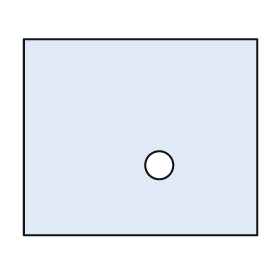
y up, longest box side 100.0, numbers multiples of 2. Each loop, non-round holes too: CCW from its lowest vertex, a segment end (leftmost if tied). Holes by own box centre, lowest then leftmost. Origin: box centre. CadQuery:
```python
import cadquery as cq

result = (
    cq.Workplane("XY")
    .moveTo(-50.0, -42.0)
    .lineTo(50.0, -42.0)
    .lineTo(50.0, 42.0)
    .lineTo(-50.0, 42.0)
    .close()
    .moveTo(8.0, -12.0)
    .circle(6.0)
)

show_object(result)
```